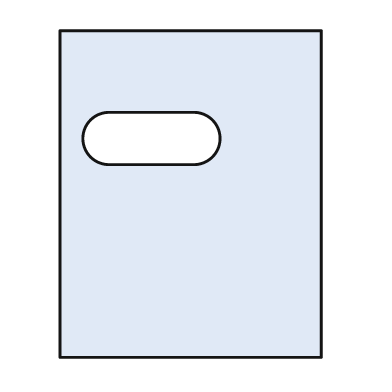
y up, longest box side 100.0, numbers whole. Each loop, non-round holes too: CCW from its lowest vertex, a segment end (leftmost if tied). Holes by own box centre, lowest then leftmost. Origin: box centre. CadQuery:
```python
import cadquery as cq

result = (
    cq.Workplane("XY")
    .moveTo(-40.0, -50.0)
    .lineTo(40.0, -50.0)
    .lineTo(40.0, 50.0)
    .lineTo(-40.0, 50.0)
    .close()
    .moveTo(-25.0, 9.0)
    .lineTo(1.0, 9.0)
    .threePointArc((9.0, 17.0), (1.0, 25.0))
    .lineTo(-25.0, 25.0)
    .threePointArc((-33.0, 17.0), (-25.0, 9.0))
    .close()
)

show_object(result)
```